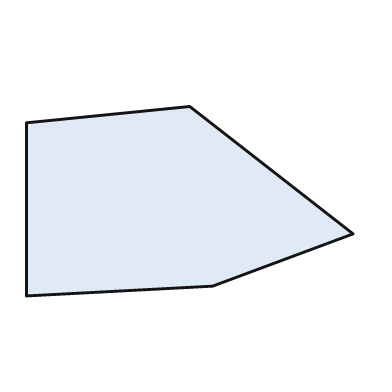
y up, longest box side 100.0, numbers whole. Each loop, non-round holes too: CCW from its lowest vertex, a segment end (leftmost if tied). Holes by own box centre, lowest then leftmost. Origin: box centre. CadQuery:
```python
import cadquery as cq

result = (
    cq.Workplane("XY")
    .moveTo(-50.0, -29.0)
    .lineTo(7.0, -26.0)
    .lineTo(50.0, -10.0)
    .lineTo(0.0, 29.0)
    .lineTo(-50.0, 24.0)
    .close()
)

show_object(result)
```